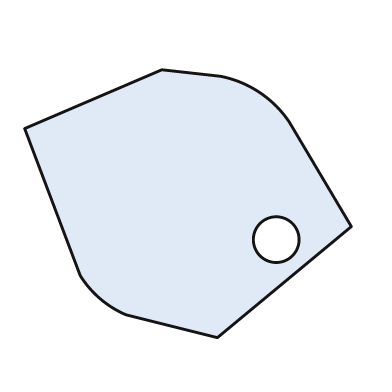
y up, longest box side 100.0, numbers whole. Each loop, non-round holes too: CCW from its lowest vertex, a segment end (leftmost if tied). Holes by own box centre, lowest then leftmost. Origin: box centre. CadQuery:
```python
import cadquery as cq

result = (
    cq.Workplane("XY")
    .moveTo(9.0, -41.0)
    .lineTo(50.0, -7.0)
    .lineTo(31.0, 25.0)
    .threePointArc((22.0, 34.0), (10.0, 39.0))
    .lineTo(-8.0, 41.0)
    .lineTo(-50.0, 23.0)
    .lineTo(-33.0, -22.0)
    .threePointArc((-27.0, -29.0), (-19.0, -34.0))
    .close()
    .moveTo(27.0, -11.0)
    .circle(7.0)
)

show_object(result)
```